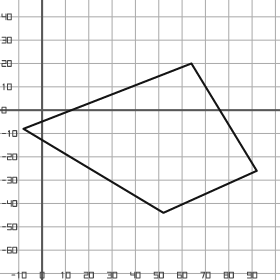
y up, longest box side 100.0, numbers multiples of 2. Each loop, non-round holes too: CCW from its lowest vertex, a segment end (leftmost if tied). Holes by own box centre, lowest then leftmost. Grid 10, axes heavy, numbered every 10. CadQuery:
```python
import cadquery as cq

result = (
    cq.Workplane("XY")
    .moveTo(52.0, -44.0)
    .lineTo(92.0, -26.0)
    .lineTo(64.0, 20.0)
    .lineTo(-8.0, -8.0)
    .close()
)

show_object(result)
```